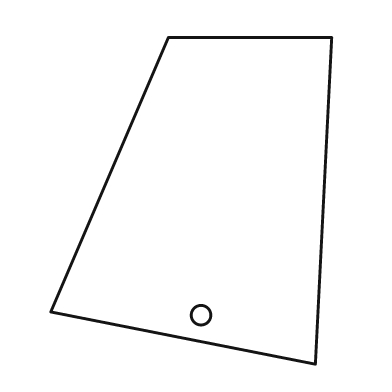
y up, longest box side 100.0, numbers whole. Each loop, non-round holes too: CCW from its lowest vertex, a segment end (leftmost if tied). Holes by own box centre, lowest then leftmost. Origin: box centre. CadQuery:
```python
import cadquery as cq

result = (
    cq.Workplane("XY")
    .moveTo(38.0, -50.0)
    .lineTo(43.0, 50.0)
    .lineTo(-7.0, 50.0)
    .lineTo(-43.0, -34.0)
    .close()
    .moveTo(3.0, -35.0)
    .circle(3.0)
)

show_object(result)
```